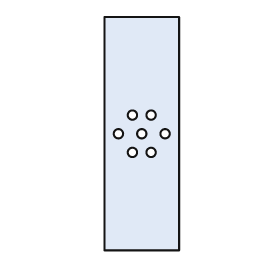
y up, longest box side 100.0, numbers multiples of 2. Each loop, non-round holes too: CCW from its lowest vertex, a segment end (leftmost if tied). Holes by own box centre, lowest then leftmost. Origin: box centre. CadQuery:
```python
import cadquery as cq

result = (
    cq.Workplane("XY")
    .moveTo(-16.0, -50.0)
    .lineTo(16.0, -50.0)
    .lineTo(16.0, 50.0)
    .lineTo(-16.0, 50.0)
    .close()
    .moveTo(-4.0, -8.0)
    .circle(2.0)
    .moveTo(4.0, -8.0)
    .circle(2.0)
    .moveTo(-10.0, 0.0)
    .circle(2.0)
    .moveTo(0.0, 0.0)
    .circle(2.0)
    .moveTo(10.0, 0.0)
    .circle(2.0)
    .moveTo(-4.0, 8.0)
    .circle(2.0)
    .moveTo(4.0, 8.0)
    .circle(2.0)
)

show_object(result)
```